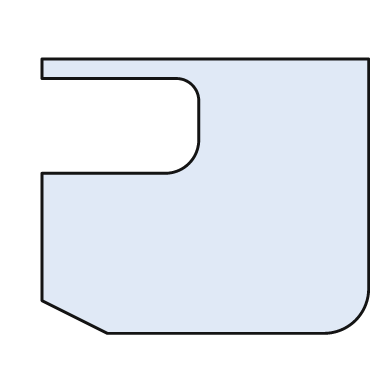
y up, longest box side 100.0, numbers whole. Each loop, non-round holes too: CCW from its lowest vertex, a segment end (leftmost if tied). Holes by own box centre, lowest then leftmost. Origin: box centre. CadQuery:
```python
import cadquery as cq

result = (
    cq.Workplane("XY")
    .moveTo(-30.0, -42.0)
    .lineTo(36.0, -42.0)
    .threePointArc((46.0, -38.0), (50.0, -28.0))
    .lineTo(50.0, 42.0)
    .lineTo(-50.0, 42.0)
    .lineTo(-50.0, 36.0)
    .lineTo(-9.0, 36.0)
    .threePointArc((-4.0, 34.0), (-2.0, 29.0))
    .lineTo(-2.0, 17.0)
    .threePointArc((-5.0, 10.0), (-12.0, 7.0))
    .lineTo(-50.0, 7.0)
    .lineTo(-50.0, -32.0)
    .close()
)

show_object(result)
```